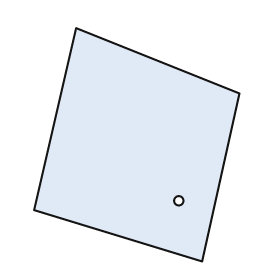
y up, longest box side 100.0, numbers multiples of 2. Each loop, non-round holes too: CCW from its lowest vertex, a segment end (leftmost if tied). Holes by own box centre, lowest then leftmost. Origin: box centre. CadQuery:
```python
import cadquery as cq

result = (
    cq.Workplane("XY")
    .moveTo(28.0, -50.0)
    .lineTo(44.0, 22.0)
    .lineTo(-26.0, 50.0)
    .lineTo(-44.0, -28.0)
    .close()
    .moveTo(18.0, -24.0)
    .circle(2.0)
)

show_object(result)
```